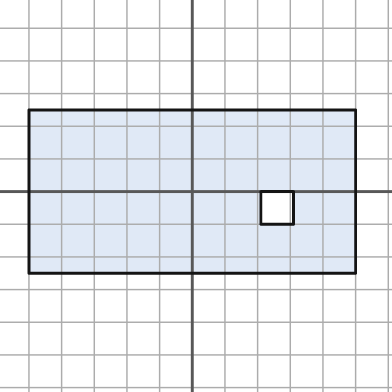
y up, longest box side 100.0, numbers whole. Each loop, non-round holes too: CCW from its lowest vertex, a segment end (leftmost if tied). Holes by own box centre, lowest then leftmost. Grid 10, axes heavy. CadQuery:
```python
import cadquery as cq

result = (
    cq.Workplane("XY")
    .moveTo(-50.0, -25.0)
    .lineTo(50.0, -25.0)
    .lineTo(50.0, 25.0)
    .lineTo(-50.0, 25.0)
    .close()
    .moveTo(21.0, -10.0)
    .lineTo(31.0, -10.0)
    .lineTo(31.0, 0.0)
    .lineTo(21.0, 0.0)
    .close()
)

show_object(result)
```